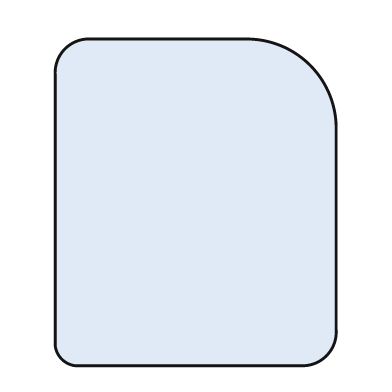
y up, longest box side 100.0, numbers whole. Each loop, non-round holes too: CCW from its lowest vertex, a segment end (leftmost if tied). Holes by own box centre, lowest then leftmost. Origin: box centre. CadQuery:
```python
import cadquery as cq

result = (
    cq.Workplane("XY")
    .moveTo(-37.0, -50.0)
    .lineTo(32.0, -50.0)
    .threePointArc((40.0, -47.0), (43.0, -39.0))
    .lineTo(43.0, 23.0)
    .threePointArc((35.0, 42.0), (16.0, 50.0))
    .lineTo(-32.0, 50.0)
    .threePointArc((-40.0, 47.0), (-43.0, 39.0))
    .lineTo(-43.0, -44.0)
    .threePointArc((-41.0, -48.0), (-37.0, -50.0))
    .close()
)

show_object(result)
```